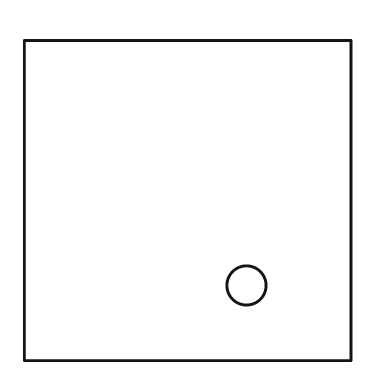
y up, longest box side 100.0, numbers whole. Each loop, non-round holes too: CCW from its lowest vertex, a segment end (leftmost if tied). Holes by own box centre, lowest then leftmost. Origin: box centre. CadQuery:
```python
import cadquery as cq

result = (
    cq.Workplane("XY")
    .moveTo(-50.0, -49.0)
    .lineTo(50.0, -49.0)
    .lineTo(50.0, 49.0)
    .lineTo(-50.0, 49.0)
    .close()
    .moveTo(18.0, -26.0)
    .circle(6.0)
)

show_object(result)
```